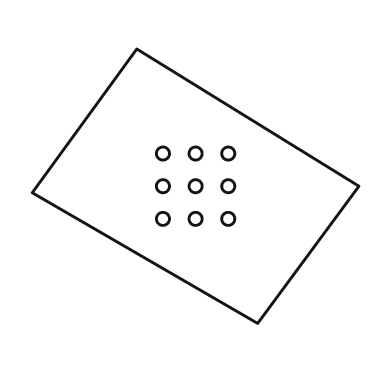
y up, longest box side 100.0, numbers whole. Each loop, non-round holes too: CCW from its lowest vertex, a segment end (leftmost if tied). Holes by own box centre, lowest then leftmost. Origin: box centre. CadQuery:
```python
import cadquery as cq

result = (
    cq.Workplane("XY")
    .moveTo(19.0, -42.0)
    .lineTo(50.0, 0.0)
    .lineTo(-18.0, 42.0)
    .lineTo(-50.0, -2.0)
    .close()
    .moveTo(-10.0, -10.0)
    .circle(2.0)
    .moveTo(0.0, -10.0)
    .circle(2.0)
    .moveTo(10.0, -10.0)
    .circle(2.0)
    .moveTo(-10.0, 0.0)
    .circle(2.0)
    .moveTo(0.0, 0.0)
    .circle(2.0)
    .moveTo(10.0, 0.0)
    .circle(2.0)
    .moveTo(-10.0, 10.0)
    .circle(2.0)
    .moveTo(0.0, 10.0)
    .circle(2.0)
    .moveTo(10.0, 10.0)
    .circle(2.0)
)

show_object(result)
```